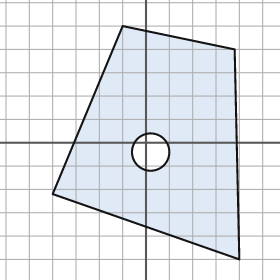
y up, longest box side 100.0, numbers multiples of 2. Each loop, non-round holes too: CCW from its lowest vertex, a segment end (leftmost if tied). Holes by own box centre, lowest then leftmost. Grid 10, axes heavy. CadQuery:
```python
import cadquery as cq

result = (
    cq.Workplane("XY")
    .moveTo(40.0, -50.0)
    .lineTo(38.0, 40.0)
    .lineTo(-10.0, 50.0)
    .lineTo(-40.0, -22.0)
    .close()
    .moveTo(2.0, -4.0)
    .circle(8.0)
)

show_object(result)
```